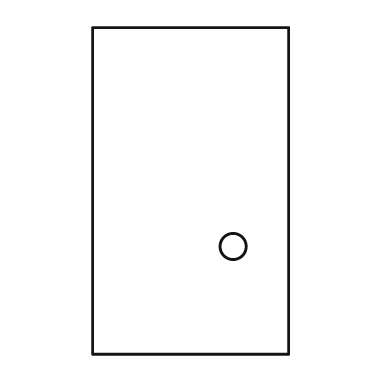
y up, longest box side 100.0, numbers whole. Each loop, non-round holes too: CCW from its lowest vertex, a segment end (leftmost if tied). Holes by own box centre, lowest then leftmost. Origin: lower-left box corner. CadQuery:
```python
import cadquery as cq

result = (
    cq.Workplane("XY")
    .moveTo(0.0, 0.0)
    .lineTo(60.0, 0.0)
    .lineTo(60.0, 100.0)
    .lineTo(0.0, 100.0)
    .close()
    .moveTo(43.0, 33.0)
    .circle(4.0)
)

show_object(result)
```